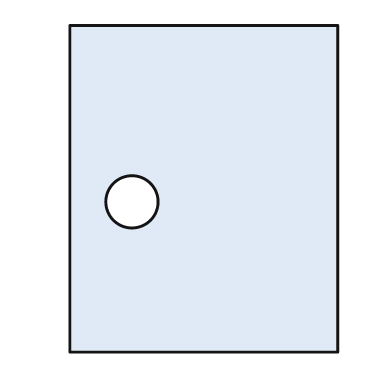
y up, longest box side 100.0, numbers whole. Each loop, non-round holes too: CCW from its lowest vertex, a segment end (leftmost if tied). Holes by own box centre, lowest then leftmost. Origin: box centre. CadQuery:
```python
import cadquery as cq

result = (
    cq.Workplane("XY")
    .moveTo(-41.0, -50.0)
    .lineTo(41.0, -50.0)
    .lineTo(41.0, 50.0)
    .lineTo(-41.0, 50.0)
    .close()
    .moveTo(-22.0, -4.0)
    .circle(8.0)
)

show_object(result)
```